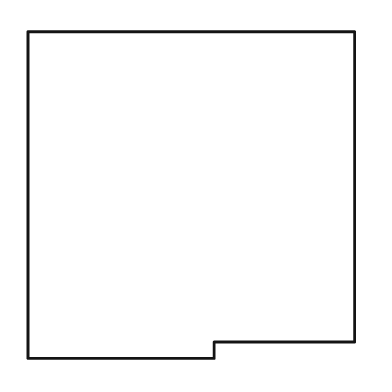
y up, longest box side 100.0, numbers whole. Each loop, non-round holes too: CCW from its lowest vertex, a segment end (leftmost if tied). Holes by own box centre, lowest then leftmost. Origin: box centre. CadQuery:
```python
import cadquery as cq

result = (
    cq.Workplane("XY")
    .moveTo(-50.0, -50.0)
    .lineTo(7.0, -50.0)
    .lineTo(7.0, -45.0)
    .lineTo(50.0, -45.0)
    .lineTo(50.0, 50.0)
    .lineTo(-50.0, 50.0)
    .close()
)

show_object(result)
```